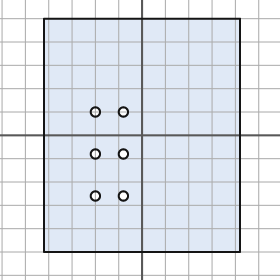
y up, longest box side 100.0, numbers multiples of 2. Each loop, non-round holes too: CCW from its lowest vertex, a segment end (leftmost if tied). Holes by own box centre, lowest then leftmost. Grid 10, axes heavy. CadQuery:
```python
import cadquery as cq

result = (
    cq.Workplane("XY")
    .moveTo(-42.0, -50.0)
    .lineTo(42.0, -50.0)
    .lineTo(42.0, 50.0)
    .lineTo(-42.0, 50.0)
    .close()
    .moveTo(-20.0, -26.0)
    .circle(2.0)
    .moveTo(-8.0, -26.0)
    .circle(2.0)
    .moveTo(-20.0, -8.0)
    .circle(2.0)
    .moveTo(-8.0, -8.0)
    .circle(2.0)
    .moveTo(-20.0, 10.0)
    .circle(2.0)
    .moveTo(-8.0, 10.0)
    .circle(2.0)
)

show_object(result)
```